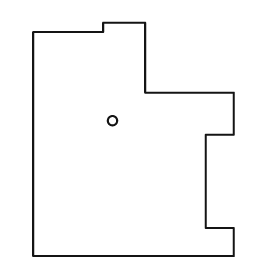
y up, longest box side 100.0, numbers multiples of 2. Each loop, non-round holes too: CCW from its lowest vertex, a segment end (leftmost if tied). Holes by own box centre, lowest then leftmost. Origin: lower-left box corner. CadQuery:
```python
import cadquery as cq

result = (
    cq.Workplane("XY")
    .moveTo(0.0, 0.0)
    .lineTo(86.0, 0.0)
    .lineTo(86.0, 12.0)
    .lineTo(74.0, 12.0)
    .lineTo(74.0, 52.0)
    .lineTo(86.0, 52.0)
    .lineTo(86.0, 70.0)
    .lineTo(48.0, 70.0)
    .lineTo(48.0, 100.0)
    .lineTo(30.0, 100.0)
    .lineTo(30.0, 96.0)
    .lineTo(0.0, 96.0)
    .close()
    .moveTo(34.0, 58.0)
    .circle(2.0)
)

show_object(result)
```